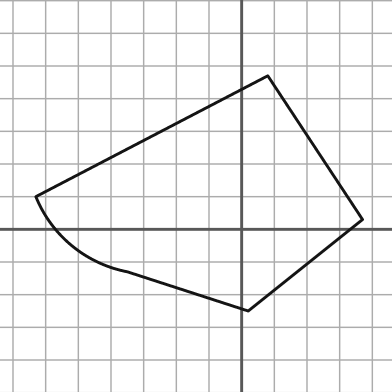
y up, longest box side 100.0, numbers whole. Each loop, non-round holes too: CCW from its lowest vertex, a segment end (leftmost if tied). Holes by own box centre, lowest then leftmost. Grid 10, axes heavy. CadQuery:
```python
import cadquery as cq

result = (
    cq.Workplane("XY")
    .moveTo(2.0, -25.0)
    .lineTo(37.0, 3.0)
    .lineTo(8.0, 47.0)
    .lineTo(-63.0, 10.0)
    .threePointArc((-52.0, -5.0), (-35.0, -13.0))
    .close()
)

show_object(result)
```